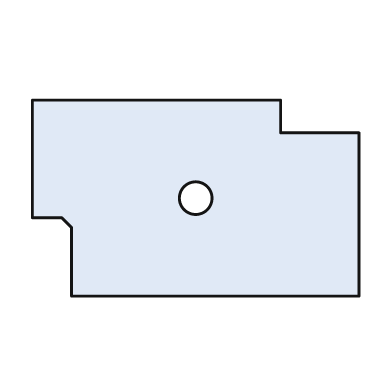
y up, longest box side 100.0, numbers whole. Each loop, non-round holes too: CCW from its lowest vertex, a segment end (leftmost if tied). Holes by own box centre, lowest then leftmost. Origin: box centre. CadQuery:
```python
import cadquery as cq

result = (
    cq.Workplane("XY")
    .moveTo(-38.0, -30.0)
    .lineTo(50.0, -30.0)
    .lineTo(50.0, 20.0)
    .lineTo(26.0, 20.0)
    .lineTo(26.0, 30.0)
    .lineTo(-50.0, 30.0)
    .lineTo(-50.0, -6.0)
    .lineTo(-41.0, -6.0)
    .lineTo(-38.0, -9.0)
    .close()
    .moveTo(0.0, 0.0)
    .circle(5.0)
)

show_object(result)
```